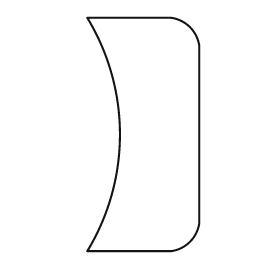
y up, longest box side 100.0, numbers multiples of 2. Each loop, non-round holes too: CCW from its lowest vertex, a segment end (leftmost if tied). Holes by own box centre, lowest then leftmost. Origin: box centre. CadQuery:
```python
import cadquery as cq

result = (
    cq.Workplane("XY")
    .moveTo(-24.0, -50.0)
    .lineTo(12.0, -50.0)
    .threePointArc((20.0, -46.0), (24.0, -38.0))
    .lineTo(24.0, 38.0)
    .threePointArc((20.0, 46.0), (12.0, 50.0))
    .lineTo(-24.0, 50.0)
    .threePointArc((-10.0, 0.0), (-24.0, -50.0))
    .close()
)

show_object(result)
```